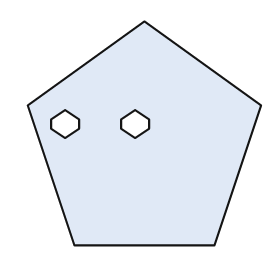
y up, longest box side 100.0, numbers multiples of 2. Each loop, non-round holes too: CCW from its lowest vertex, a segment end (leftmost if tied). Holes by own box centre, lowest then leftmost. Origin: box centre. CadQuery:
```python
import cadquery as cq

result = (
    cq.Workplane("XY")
    .moveTo(-30.0, -48.0)
    .lineTo(30.0, -48.0)
    .lineTo(50.0, 12.0)
    .lineTo(0.0, 48.0)
    .lineTo(-50.0, 12.0)
    .close()
    .moveTo(-34.0, -2.0)
    .lineTo(-28.0, 2.0)
    .lineTo(-28.0, 6.0)
    .lineTo(-34.0, 10.0)
    .lineTo(-40.0, 6.0)
    .lineTo(-40.0, 2.0)
    .close()
    .moveTo(-4.0, -2.0)
    .lineTo(2.0, 2.0)
    .lineTo(2.0, 6.0)
    .lineTo(-4.0, 10.0)
    .lineTo(-10.0, 6.0)
    .lineTo(-10.0, 2.0)
    .close()
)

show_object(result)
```